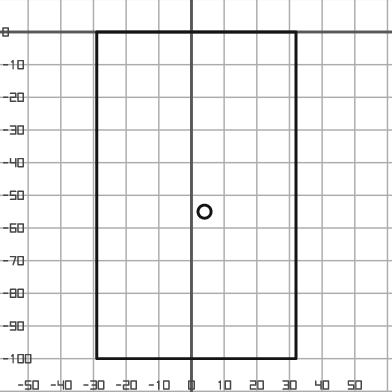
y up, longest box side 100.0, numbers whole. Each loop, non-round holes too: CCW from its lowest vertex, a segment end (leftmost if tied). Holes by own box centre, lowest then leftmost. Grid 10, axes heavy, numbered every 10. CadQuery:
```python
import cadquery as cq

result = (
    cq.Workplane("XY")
    .moveTo(-29.0, -100.0)
    .lineTo(32.0, -100.0)
    .lineTo(32.0, 0.0)
    .lineTo(-29.0, 0.0)
    .close()
    .moveTo(4.0, -55.0)
    .circle(2.0)
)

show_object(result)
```